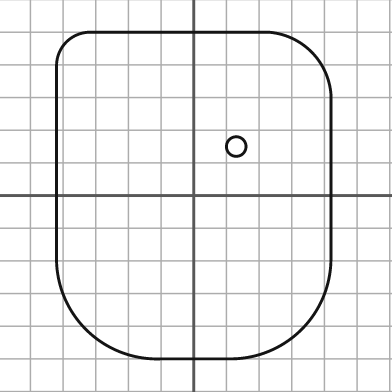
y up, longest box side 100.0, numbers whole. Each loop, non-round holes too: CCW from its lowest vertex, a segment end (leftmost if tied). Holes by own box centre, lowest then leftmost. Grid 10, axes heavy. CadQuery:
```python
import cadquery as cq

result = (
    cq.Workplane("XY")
    .moveTo(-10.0, -50.0)
    .lineTo(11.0, -50.0)
    .threePointArc((33.0, -41.0), (42.0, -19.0))
    .lineTo(42.0, 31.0)
    .threePointArc((36.0, 44.0), (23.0, 50.0))
    .lineTo(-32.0, 50.0)
    .threePointArc((-39.0, 47.0), (-42.0, 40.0))
    .lineTo(-42.0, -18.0)
    .threePointArc((-33.0, -41.0), (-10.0, -50.0))
    .close()
    .moveTo(13.0, 15.0)
    .circle(3.0)
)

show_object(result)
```